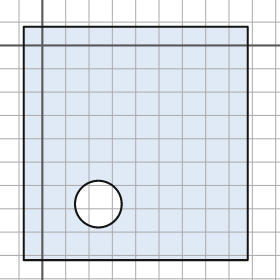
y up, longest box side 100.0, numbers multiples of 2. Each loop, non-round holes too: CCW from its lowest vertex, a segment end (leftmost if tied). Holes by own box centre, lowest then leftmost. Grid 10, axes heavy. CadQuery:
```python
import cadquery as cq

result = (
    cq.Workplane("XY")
    .moveTo(-8.0, -92.0)
    .lineTo(88.0, -92.0)
    .lineTo(88.0, 8.0)
    .lineTo(-8.0, 8.0)
    .close()
    .moveTo(24.0, -68.0)
    .circle(10.0)
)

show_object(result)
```